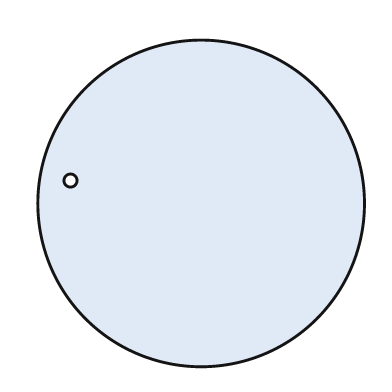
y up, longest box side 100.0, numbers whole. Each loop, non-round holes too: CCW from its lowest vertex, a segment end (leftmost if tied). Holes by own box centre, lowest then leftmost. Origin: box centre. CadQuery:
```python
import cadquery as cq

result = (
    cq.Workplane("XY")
    .moveTo(0.0, 0.0)
    .circle(50.0)
    .moveTo(-40.0, 7.0)
    .circle(2.0)
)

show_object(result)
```